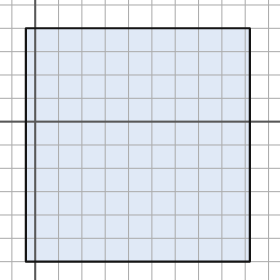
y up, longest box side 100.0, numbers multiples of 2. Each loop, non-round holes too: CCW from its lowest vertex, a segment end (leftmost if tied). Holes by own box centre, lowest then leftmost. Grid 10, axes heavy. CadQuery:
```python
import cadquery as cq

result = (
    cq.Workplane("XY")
    .moveTo(-4.0, -60.0)
    .lineTo(92.0, -60.0)
    .lineTo(92.0, 40.0)
    .lineTo(-4.0, 40.0)
    .close()
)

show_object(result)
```